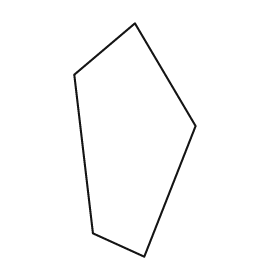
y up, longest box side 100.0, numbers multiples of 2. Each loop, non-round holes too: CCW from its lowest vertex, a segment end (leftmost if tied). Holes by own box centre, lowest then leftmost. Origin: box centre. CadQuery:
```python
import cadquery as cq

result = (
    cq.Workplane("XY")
    .moveTo(4.0, -50.0)
    .lineTo(26.0, 6.0)
    .lineTo(0.0, 50.0)
    .lineTo(-26.0, 28.0)
    .lineTo(-18.0, -40.0)
    .close()
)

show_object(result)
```